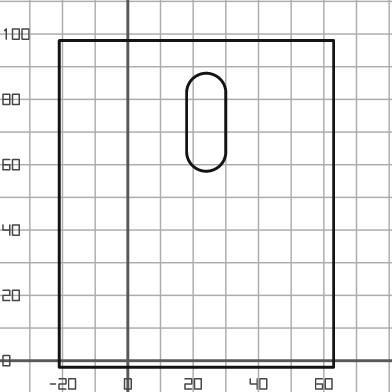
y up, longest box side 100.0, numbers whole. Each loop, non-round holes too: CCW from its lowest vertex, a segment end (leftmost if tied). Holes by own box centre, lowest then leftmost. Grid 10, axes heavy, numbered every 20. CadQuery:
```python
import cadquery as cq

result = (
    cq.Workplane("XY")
    .moveTo(-21.0, -2.0)
    .lineTo(63.0, -2.0)
    .lineTo(63.0, 98.0)
    .lineTo(-21.0, 98.0)
    .close()
    .moveTo(18.0, 64.0)
    .threePointArc((24.0, 58.0), (30.0, 64.0))
    .lineTo(30.0, 82.0)
    .threePointArc((24.0, 88.0), (18.0, 82.0))
    .close()
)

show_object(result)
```